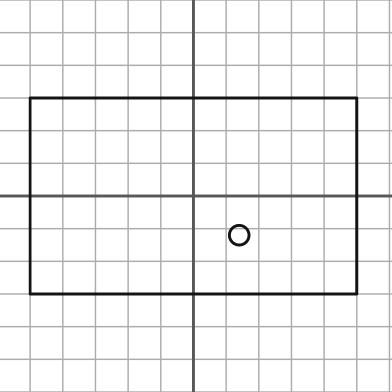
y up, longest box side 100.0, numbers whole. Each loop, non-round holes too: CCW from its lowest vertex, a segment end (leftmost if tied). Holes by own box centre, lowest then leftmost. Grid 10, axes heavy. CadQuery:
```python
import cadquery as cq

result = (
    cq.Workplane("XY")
    .moveTo(-50.0, -30.0)
    .lineTo(50.0, -30.0)
    .lineTo(50.0, 30.0)
    .lineTo(-50.0, 30.0)
    .close()
    .moveTo(14.0, -12.0)
    .circle(3.0)
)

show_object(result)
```